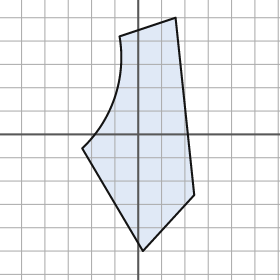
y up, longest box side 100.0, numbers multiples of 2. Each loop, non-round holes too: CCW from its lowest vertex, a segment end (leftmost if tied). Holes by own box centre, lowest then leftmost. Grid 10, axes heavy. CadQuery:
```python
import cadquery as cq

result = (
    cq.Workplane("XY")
    .moveTo(2.0, -50.0)
    .lineTo(24.0, -26.0)
    .lineTo(16.0, 50.0)
    .lineTo(-8.0, 42.0)
    .threePointArc((-10.0, 16.0), (-24.0, -6.0))
    .close()
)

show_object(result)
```